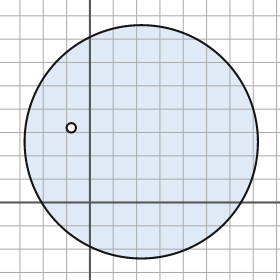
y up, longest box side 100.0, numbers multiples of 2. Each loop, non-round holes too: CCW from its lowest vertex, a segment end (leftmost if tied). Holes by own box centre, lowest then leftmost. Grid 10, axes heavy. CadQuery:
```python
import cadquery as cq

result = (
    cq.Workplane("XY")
    .moveTo(22.0, 26.0)
    .circle(50.0)
    .moveTo(-8.0, 32.0)
    .circle(2.0)
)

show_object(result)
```